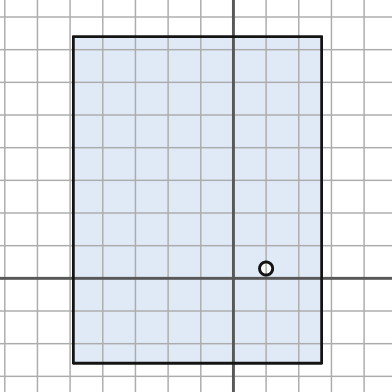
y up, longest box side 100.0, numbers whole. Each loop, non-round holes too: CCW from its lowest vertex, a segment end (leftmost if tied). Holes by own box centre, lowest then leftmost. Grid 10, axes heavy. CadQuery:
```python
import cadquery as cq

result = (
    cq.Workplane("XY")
    .moveTo(-49.0, -26.0)
    .lineTo(27.0, -26.0)
    .lineTo(27.0, 74.0)
    .lineTo(-49.0, 74.0)
    .close()
    .moveTo(10.0, 3.0)
    .circle(2.0)
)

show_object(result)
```